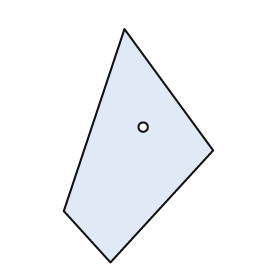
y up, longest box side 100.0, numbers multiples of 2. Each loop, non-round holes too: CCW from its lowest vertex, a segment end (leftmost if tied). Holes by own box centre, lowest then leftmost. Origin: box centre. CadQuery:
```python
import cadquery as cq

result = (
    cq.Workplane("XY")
    .moveTo(-12.0, -50.0)
    .lineTo(32.0, -2.0)
    .lineTo(-6.0, 50.0)
    .lineTo(-32.0, -28.0)
    .close()
    .moveTo(2.0, 8.0)
    .circle(2.0)
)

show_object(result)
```